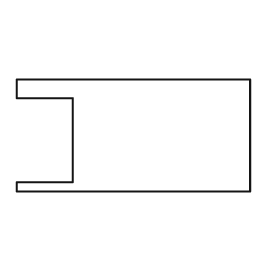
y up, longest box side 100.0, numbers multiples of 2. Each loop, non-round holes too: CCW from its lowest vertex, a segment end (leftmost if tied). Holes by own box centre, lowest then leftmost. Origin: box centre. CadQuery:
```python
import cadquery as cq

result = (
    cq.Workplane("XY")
    .moveTo(-50.0, -24.0)
    .lineTo(50.0, -24.0)
    .lineTo(50.0, 24.0)
    .lineTo(-50.0, 24.0)
    .lineTo(-50.0, 16.0)
    .lineTo(-26.0, 16.0)
    .lineTo(-26.0, -20.0)
    .lineTo(-50.0, -20.0)
    .close()
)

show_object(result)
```